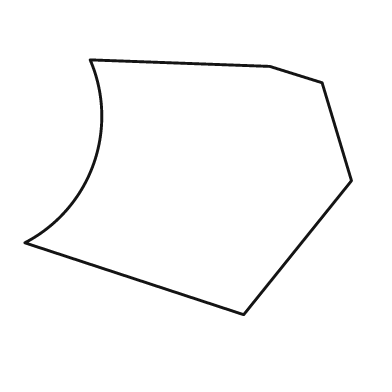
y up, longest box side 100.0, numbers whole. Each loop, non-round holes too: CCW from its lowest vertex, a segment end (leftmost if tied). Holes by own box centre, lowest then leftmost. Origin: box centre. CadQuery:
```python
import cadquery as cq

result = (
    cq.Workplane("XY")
    .moveTo(17.0, -39.0)
    .lineTo(50.0, 2.0)
    .lineTo(41.0, 32.0)
    .lineTo(25.0, 37.0)
    .lineTo(-30.0, 39.0)
    .threePointArc((-29.0, 7.0), (-50.0, -17.0))
    .close()
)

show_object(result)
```